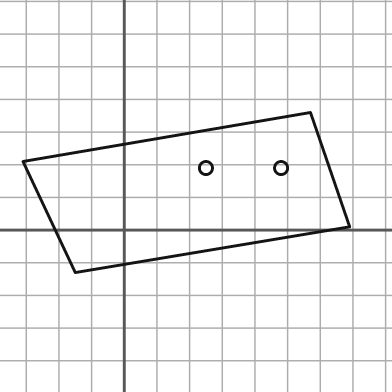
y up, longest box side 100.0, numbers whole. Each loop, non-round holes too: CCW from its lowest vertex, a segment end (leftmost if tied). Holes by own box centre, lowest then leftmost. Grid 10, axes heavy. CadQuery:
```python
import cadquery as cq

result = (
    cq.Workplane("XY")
    .moveTo(-15.0, -13.0)
    .lineTo(69.0, 1.0)
    .lineTo(57.0, 36.0)
    .lineTo(-31.0, 21.0)
    .close()
    .moveTo(25.0, 19.0)
    .circle(2.0)
    .moveTo(48.0, 19.0)
    .circle(2.0)
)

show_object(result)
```